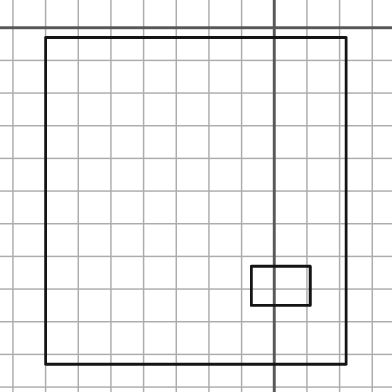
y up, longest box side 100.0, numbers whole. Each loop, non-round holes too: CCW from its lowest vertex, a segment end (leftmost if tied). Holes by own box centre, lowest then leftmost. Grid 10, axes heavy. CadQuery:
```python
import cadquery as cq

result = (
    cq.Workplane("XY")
    .moveTo(-70.0, -103.0)
    .lineTo(22.0, -103.0)
    .lineTo(22.0, -3.0)
    .lineTo(-70.0, -3.0)
    .close()
    .moveTo(-7.0, -85.0)
    .lineTo(11.0, -85.0)
    .lineTo(11.0, -73.0)
    .lineTo(-7.0, -73.0)
    .close()
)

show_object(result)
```